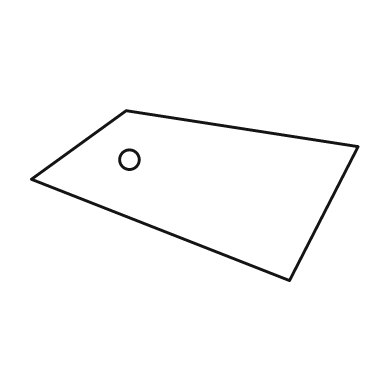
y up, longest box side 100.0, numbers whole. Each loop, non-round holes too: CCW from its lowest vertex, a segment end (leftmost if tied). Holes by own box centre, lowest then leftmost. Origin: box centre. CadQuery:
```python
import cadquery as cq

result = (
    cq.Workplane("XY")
    .moveTo(29.0, -26.0)
    .lineTo(50.0, 15.0)
    .lineTo(-21.0, 26.0)
    .lineTo(-50.0, 5.0)
    .close()
    .moveTo(-20.0, 11.0)
    .circle(3.0)
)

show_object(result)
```